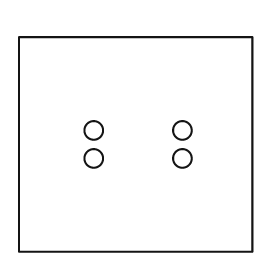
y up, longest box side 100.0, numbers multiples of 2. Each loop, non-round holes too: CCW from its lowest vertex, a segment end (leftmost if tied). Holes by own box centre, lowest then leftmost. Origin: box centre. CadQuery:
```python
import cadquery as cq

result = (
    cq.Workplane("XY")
    .moveTo(-50.0, -46.0)
    .lineTo(50.0, -46.0)
    .lineTo(50.0, 46.0)
    .lineTo(-50.0, 46.0)
    .close()
    .moveTo(-18.0, -6.0)
    .circle(4.0)
    .moveTo(20.0, -6.0)
    .circle(4.0)
    .moveTo(-18.0, 6.0)
    .circle(4.0)
    .moveTo(20.0, 6.0)
    .circle(4.0)
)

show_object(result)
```